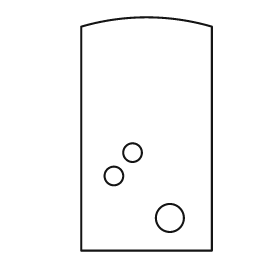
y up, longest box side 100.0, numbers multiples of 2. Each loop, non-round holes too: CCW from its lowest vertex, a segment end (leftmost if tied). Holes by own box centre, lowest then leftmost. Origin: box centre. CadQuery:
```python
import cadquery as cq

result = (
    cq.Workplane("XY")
    .moveTo(-28.0, -50.0)
    .lineTo(28.0, -50.0)
    .lineTo(28.0, 46.0)
    .threePointArc((0.0, 50.0), (-28.0, 46.0))
    .close()
    .moveTo(10.0, -36.0)
    .circle(6.0)
    .moveTo(-14.0, -18.0)
    .circle(4.0)
    .moveTo(-6.0, -8.0)
    .circle(4.0)
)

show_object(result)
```